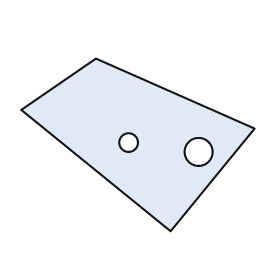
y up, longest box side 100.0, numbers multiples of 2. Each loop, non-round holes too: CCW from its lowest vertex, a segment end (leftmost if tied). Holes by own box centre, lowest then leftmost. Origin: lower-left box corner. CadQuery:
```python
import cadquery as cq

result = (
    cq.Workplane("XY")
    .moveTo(64.0, 0.0)
    .lineTo(100.0, 44.0)
    .lineTo(32.0, 74.0)
    .lineTo(0.0, 52.0)
    .close()
    .moveTo(76.0, 34.0)
    .circle(6.0)
    .moveTo(46.0, 38.0)
    .circle(4.0)
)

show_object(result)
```